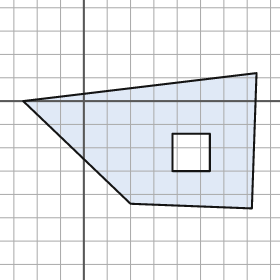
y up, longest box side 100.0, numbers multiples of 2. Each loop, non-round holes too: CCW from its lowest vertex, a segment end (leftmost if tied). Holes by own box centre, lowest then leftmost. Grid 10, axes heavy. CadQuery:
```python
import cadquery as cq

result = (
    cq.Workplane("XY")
    .moveTo(72.0, -46.0)
    .lineTo(74.0, 12.0)
    .lineTo(-26.0, 0.0)
    .lineTo(20.0, -44.0)
    .close()
    .moveTo(38.0, -30.0)
    .lineTo(54.0, -30.0)
    .lineTo(54.0, -14.0)
    .lineTo(38.0, -14.0)
    .close()
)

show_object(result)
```